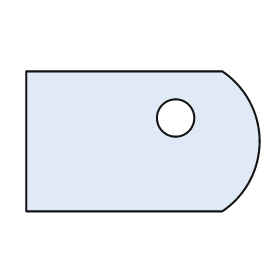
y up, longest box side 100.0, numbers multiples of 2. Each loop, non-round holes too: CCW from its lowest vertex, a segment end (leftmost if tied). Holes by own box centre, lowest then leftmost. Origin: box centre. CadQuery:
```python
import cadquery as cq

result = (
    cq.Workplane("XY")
    .moveTo(-50.0, -30.0)
    .lineTo(34.0, -30.0)
    .threePointArc((50.0, 0.0), (34.0, 30.0))
    .lineTo(-50.0, 30.0)
    .close()
    .moveTo(14.0, 10.0)
    .circle(8.0)
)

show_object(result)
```